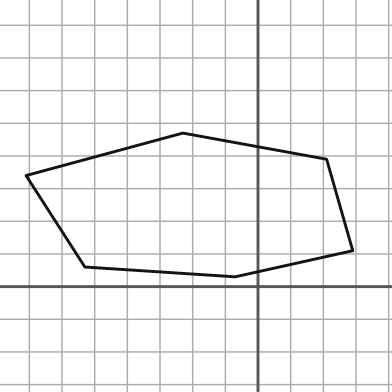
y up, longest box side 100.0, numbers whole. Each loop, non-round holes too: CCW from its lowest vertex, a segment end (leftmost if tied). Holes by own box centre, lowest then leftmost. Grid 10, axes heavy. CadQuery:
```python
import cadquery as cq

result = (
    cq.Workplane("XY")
    .moveTo(-7.0, 3.0)
    .lineTo(29.0, 11.0)
    .lineTo(21.0, 39.0)
    .lineTo(-23.0, 47.0)
    .lineTo(-71.0, 34.0)
    .lineTo(-53.0, 6.0)
    .close()
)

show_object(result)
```